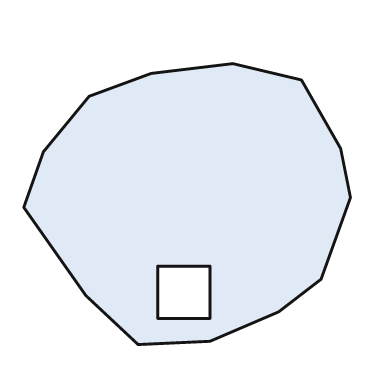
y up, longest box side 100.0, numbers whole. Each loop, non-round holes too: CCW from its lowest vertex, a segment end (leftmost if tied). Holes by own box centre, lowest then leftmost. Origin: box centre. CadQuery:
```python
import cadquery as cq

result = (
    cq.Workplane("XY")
    .moveTo(-15.0, -43.0)
    .lineTo(7.0, -42.0)
    .lineTo(28.0, -33.0)
    .lineTo(41.0, -23.0)
    .lineTo(50.0, 2.0)
    .lineTo(47.0, 17.0)
    .lineTo(35.0, 38.0)
    .lineTo(14.0, 43.0)
    .lineTo(-11.0, 40.0)
    .lineTo(-30.0, 33.0)
    .lineTo(-44.0, 16.0)
    .lineTo(-50.0, -1.0)
    .lineTo(-31.0, -28.0)
    .close()
    .moveTo(-9.0, -35.0)
    .lineTo(7.0, -35.0)
    .lineTo(7.0, -19.0)
    .lineTo(-9.0, -19.0)
    .close()
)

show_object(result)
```